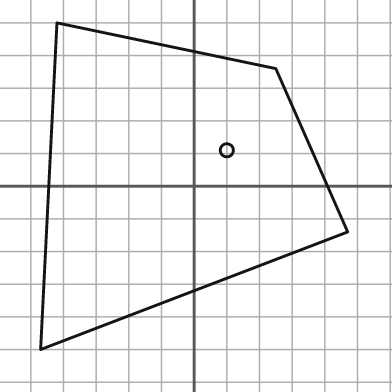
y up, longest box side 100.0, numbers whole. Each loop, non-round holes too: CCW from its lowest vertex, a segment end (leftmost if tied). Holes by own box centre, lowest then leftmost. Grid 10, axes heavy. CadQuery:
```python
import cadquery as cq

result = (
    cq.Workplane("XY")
    .moveTo(-47.0, -50.0)
    .lineTo(47.0, -14.0)
    .lineTo(25.0, 36.0)
    .lineTo(-42.0, 50.0)
    .close()
    .moveTo(10.0, 11.0)
    .circle(2.0)
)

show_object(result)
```